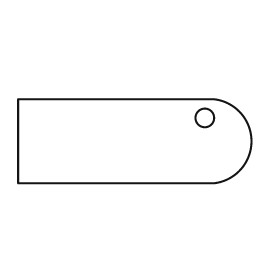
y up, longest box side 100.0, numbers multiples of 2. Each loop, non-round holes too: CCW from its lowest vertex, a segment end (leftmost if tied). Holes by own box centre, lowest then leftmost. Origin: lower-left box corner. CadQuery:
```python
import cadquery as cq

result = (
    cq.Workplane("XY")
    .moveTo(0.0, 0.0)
    .lineTo(84.0, 0.0)
    .threePointArc((100.0, 18.0), (84.0, 36.0))
    .lineTo(0.0, 36.0)
    .close()
    .moveTo(80.0, 28.0)
    .circle(4.0)
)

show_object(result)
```